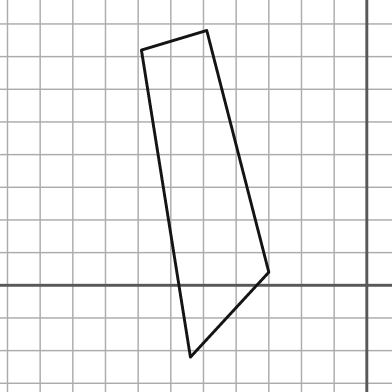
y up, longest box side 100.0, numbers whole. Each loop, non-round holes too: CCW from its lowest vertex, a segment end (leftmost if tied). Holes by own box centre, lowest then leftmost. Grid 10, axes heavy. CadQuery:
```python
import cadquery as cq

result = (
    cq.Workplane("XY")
    .moveTo(-54.0, -22.0)
    .lineTo(-30.0, 4.0)
    .lineTo(-49.0, 78.0)
    .lineTo(-69.0, 72.0)
    .close()
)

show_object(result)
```